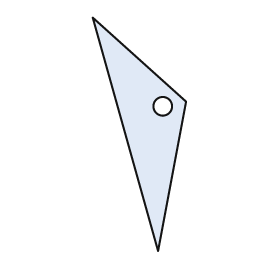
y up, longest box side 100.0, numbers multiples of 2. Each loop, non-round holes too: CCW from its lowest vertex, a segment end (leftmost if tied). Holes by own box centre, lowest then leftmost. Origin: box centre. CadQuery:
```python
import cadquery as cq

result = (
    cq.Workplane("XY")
    .moveTo(8.0, -50.0)
    .lineTo(20.0, 14.0)
    .lineTo(-20.0, 50.0)
    .close()
    .moveTo(10.0, 12.0)
    .circle(4.0)
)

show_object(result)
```